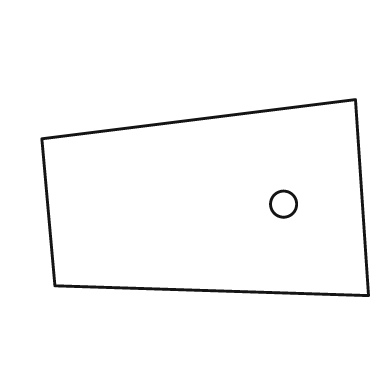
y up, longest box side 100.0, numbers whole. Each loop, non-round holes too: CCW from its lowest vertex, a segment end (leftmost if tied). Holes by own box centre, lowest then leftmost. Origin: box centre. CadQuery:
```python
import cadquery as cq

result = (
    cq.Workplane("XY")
    .moveTo(50.0, -30.0)
    .lineTo(46.0, 30.0)
    .lineTo(-50.0, 18.0)
    .lineTo(-46.0, -27.0)
    .close()
    .moveTo(24.0, -2.0)
    .circle(4.0)
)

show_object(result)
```